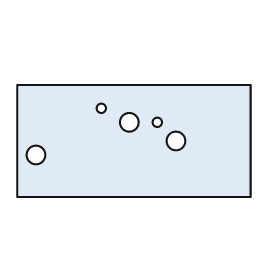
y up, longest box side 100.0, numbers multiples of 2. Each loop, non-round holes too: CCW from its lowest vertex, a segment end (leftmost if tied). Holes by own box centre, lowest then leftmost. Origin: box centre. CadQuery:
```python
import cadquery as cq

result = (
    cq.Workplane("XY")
    .moveTo(-50.0, -24.0)
    .lineTo(50.0, -24.0)
    .lineTo(50.0, 24.0)
    .lineTo(-50.0, 24.0)
    .close()
    .moveTo(-42.0, -6.0)
    .circle(4.0)
    .moveTo(18.0, 0.0)
    .circle(4.0)
    .moveTo(-2.0, 8.0)
    .circle(4.0)
    .moveTo(10.0, 8.0)
    .circle(2.0)
    .moveTo(-14.0, 14.0)
    .circle(2.0)
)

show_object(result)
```